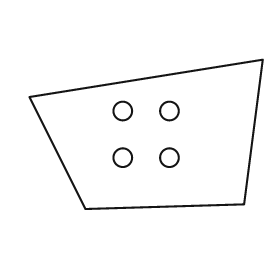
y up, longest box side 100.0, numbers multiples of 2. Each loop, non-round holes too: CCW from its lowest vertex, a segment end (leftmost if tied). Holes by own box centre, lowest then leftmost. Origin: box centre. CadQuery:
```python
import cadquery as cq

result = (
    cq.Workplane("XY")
    .moveTo(-26.0, -32.0)
    .lineTo(42.0, -30.0)
    .lineTo(50.0, 32.0)
    .lineTo(-50.0, 16.0)
    .close()
    .moveTo(-10.0, -10.0)
    .circle(4.0)
    .moveTo(10.0, -10.0)
    .circle(4.0)
    .moveTo(-10.0, 10.0)
    .circle(4.0)
    .moveTo(10.0, 10.0)
    .circle(4.0)
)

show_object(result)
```